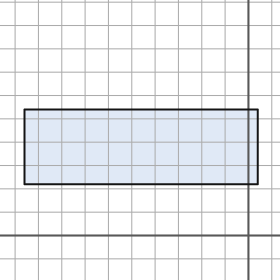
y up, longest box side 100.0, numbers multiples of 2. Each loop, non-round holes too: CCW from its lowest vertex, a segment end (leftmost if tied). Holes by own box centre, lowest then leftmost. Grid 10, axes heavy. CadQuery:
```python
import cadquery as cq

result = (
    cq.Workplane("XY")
    .moveTo(-96.0, 22.0)
    .lineTo(4.0, 22.0)
    .lineTo(4.0, 54.0)
    .lineTo(-96.0, 54.0)
    .close()
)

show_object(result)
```